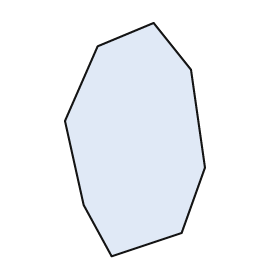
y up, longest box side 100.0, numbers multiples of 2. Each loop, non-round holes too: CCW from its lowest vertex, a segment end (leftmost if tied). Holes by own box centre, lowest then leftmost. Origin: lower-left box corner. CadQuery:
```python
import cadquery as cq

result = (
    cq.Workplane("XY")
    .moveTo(20.0, 0.0)
    .lineTo(50.0, 10.0)
    .lineTo(60.0, 38.0)
    .lineTo(54.0, 80.0)
    .lineTo(38.0, 100.0)
    .lineTo(14.0, 90.0)
    .lineTo(0.0, 58.0)
    .lineTo(8.0, 22.0)
    .close()
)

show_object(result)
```